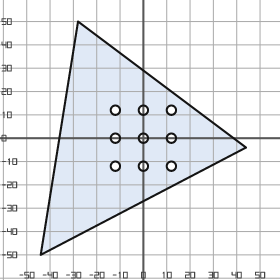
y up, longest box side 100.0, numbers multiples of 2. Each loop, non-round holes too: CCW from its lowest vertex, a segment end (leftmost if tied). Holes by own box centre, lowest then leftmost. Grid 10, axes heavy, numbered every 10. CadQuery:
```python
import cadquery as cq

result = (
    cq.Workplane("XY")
    .moveTo(-44.0, -50.0)
    .lineTo(44.0, -4.0)
    .lineTo(-28.0, 50.0)
    .close()
    .moveTo(-12.0, -12.0)
    .circle(2.0)
    .moveTo(0.0, -12.0)
    .circle(2.0)
    .moveTo(12.0, -12.0)
    .circle(2.0)
    .moveTo(-12.0, 0.0)
    .circle(2.0)
    .moveTo(0.0, 0.0)
    .circle(2.0)
    .moveTo(12.0, 0.0)
    .circle(2.0)
    .moveTo(-12.0, 12.0)
    .circle(2.0)
    .moveTo(0.0, 12.0)
    .circle(2.0)
    .moveTo(12.0, 12.0)
    .circle(2.0)
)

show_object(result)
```